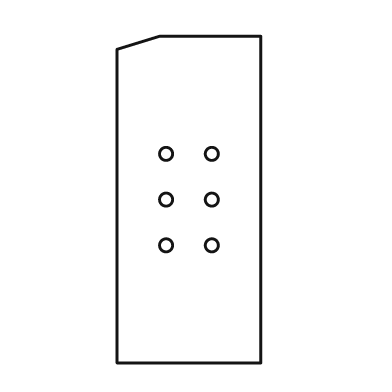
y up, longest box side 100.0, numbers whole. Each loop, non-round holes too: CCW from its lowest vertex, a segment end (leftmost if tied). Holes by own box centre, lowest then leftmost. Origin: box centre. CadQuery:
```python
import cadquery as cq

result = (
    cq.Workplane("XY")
    .moveTo(-22.0, -50.0)
    .lineTo(22.0, -50.0)
    .lineTo(22.0, 50.0)
    .lineTo(-9.0, 50.0)
    .lineTo(-22.0, 46.0)
    .close()
    .moveTo(-7.0, -14.0)
    .circle(2.0)
    .moveTo(7.0, -14.0)
    .circle(2.0)
    .moveTo(-7.0, 0.0)
    .circle(2.0)
    .moveTo(7.0, 0.0)
    .circle(2.0)
    .moveTo(-7.0, 14.0)
    .circle(2.0)
    .moveTo(7.0, 14.0)
    .circle(2.0)
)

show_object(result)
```